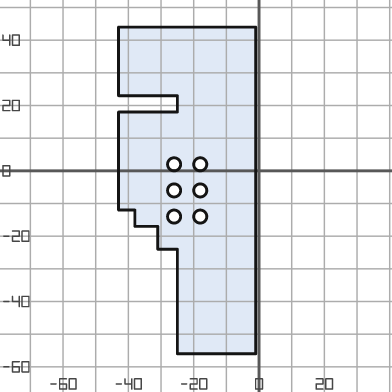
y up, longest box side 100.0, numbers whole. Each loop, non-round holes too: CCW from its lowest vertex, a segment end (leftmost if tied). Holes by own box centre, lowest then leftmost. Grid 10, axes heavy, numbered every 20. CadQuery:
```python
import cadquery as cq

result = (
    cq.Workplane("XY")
    .moveTo(-25.0, -56.0)
    .lineTo(-1.0, -56.0)
    .lineTo(-1.0, 44.0)
    .lineTo(-43.0, 44.0)
    .lineTo(-43.0, 23.0)
    .lineTo(-25.0, 23.0)
    .lineTo(-25.0, 18.0)
    .lineTo(-43.0, 18.0)
    .lineTo(-43.0, -12.0)
    .lineTo(-38.0, -12.0)
    .lineTo(-38.0, -17.0)
    .lineTo(-31.0, -17.0)
    .lineTo(-31.0, -24.0)
    .lineTo(-25.0, -24.0)
    .close()
    .moveTo(-26.0, -14.0)
    .circle(2.0)
    .moveTo(-18.0, -14.0)
    .circle(2.0)
    .moveTo(-26.0, -6.0)
    .circle(2.0)
    .moveTo(-18.0, -6.0)
    .circle(2.0)
    .moveTo(-26.0, 2.0)
    .circle(2.0)
    .moveTo(-18.0, 2.0)
    .circle(2.0)
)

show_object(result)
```